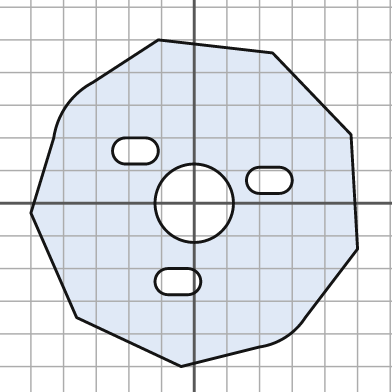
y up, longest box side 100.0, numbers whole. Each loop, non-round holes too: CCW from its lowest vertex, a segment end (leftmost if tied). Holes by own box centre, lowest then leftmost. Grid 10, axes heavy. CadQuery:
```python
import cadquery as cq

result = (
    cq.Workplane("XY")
    .moveTo(-4.0, -50.0)
    .lineTo(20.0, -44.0)
    .threePointArc((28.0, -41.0), (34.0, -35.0))
    .lineTo(50.0, -14.0)
    .lineTo(48.0, 21.0)
    .lineTo(24.0, 46.0)
    .lineTo(-11.0, 50.0)
    .lineTo(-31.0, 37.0)
    .threePointArc((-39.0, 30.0), (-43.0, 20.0))
    .lineTo(-50.0, -3.0)
    .lineTo(-36.0, -35.0)
    .close()
    .moveTo(-8.0, -28.0)
    .lineTo(-2.0, -28.0)
    .threePointArc((2.0, -24.0), (-2.0, -20.0))
    .lineTo(-8.0, -20.0)
    .threePointArc((-12.0, -24.0), (-8.0, -28.0))
    .close()
    .moveTo(0.0, 0.0)
    .circle(12.0)
    .moveTo(20.0, 3.0)
    .lineTo(26.0, 3.0)
    .threePointArc((30.0, 7.0), (26.0, 11.0))
    .lineTo(20.0, 11.0)
    .threePointArc((16.0, 7.0), (20.0, 3.0))
    .close()
    .moveTo(-21.0, 12.0)
    .lineTo(-15.0, 12.0)
    .threePointArc((-11.0, 16.0), (-15.0, 20.0))
    .lineTo(-21.0, 20.0)
    .threePointArc((-25.0, 16.0), (-21.0, 12.0))
    .close()
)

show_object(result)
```